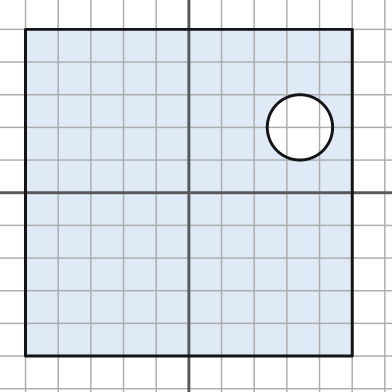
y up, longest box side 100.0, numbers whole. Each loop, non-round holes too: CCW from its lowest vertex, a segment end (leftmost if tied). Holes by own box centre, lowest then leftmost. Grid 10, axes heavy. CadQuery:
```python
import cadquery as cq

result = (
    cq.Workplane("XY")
    .moveTo(-50.0, -50.0)
    .lineTo(50.0, -50.0)
    .lineTo(50.0, 50.0)
    .lineTo(-50.0, 50.0)
    .close()
    .moveTo(34.0, 20.0)
    .circle(10.0)
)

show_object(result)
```